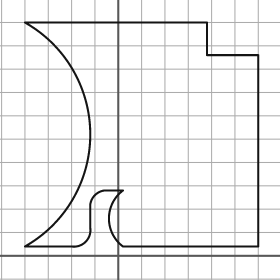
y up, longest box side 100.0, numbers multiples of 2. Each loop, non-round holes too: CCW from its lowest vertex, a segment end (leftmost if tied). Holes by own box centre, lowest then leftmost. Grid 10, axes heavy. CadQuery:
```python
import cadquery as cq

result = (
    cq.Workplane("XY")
    .moveTo(-40.0, 4.0)
    .lineTo(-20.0, 4.0)
    .threePointArc((-14.0, 6.0), (-12.0, 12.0))
    .lineTo(-12.0, 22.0)
    .threePointArc((-10.0, 26.0), (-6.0, 28.0))
    .lineTo(2.0, 28.0)
    .threePointArc((-4.0, 16.0), (2.0, 4.0))
    .lineTo(60.0, 4.0)
    .lineTo(60.0, 86.0)
    .lineTo(38.0, 86.0)
    .lineTo(38.0, 100.0)
    .lineTo(-40.0, 100.0)
    .threePointArc((-12.0, 52.0), (-40.0, 4.0))
    .close()
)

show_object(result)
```